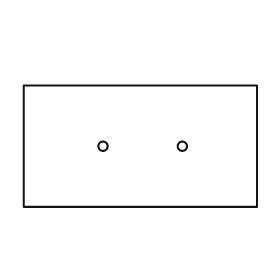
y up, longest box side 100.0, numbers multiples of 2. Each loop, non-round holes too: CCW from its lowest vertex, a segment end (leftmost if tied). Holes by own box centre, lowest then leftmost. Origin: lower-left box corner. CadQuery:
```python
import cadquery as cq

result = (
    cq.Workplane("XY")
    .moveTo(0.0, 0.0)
    .lineTo(100.0, 0.0)
    .lineTo(100.0, 52.0)
    .lineTo(0.0, 52.0)
    .close()
    .moveTo(34.0, 26.0)
    .circle(2.0)
    .moveTo(68.0, 26.0)
    .circle(2.0)
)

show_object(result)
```